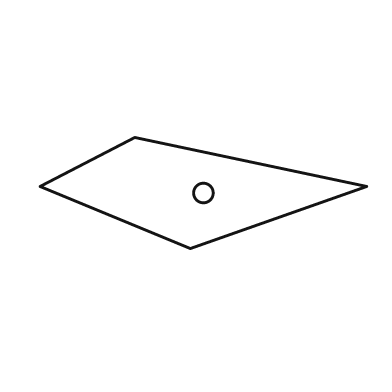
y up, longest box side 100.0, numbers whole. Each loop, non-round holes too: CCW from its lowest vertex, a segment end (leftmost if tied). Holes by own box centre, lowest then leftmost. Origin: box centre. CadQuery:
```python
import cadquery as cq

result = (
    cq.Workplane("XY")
    .moveTo(-4.0, -17.0)
    .lineTo(50.0, 2.0)
    .lineTo(-21.0, 17.0)
    .lineTo(-50.0, 2.0)
    .close()
    .moveTo(0.0, 0.0)
    .circle(3.0)
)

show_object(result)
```